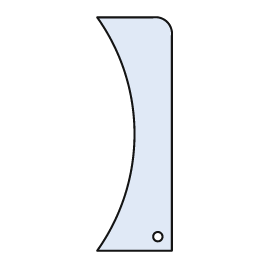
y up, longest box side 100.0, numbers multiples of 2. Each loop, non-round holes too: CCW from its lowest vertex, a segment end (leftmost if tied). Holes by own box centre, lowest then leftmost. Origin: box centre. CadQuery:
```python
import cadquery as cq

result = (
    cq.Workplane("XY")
    .moveTo(-16.0, -50.0)
    .lineTo(16.0, -50.0)
    .lineTo(16.0, 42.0)
    .threePointArc((14.0, 48.0), (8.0, 50.0))
    .lineTo(-16.0, 50.0)
    .threePointArc((0.0, 0.0), (-16.0, -50.0))
    .close()
    .moveTo(10.0, -44.0)
    .circle(2.0)
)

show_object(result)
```